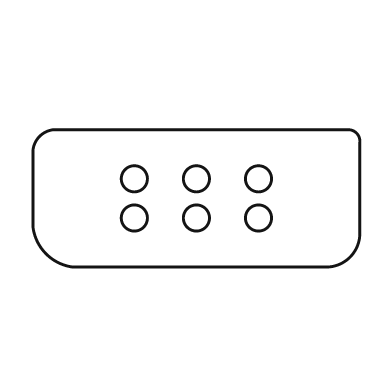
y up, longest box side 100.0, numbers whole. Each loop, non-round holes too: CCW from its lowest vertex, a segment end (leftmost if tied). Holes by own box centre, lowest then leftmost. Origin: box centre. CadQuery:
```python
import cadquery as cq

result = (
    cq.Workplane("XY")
    .moveTo(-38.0, -21.0)
    .lineTo(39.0, -21.0)
    .threePointArc((47.0, -18.0), (50.0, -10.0))
    .lineTo(50.0, 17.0)
    .threePointArc((49.0, 20.0), (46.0, 21.0))
    .lineTo(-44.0, 21.0)
    .threePointArc((-48.0, 19.0), (-50.0, 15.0))
    .lineTo(-50.0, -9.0)
    .threePointArc((-46.0, -17.0), (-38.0, -21.0))
    .close()
    .moveTo(-19.0, -6.0)
    .circle(4.0)
    .moveTo(0.0, -6.0)
    .circle(4.0)
    .moveTo(19.0, -6.0)
    .circle(4.0)
    .moveTo(-19.0, 6.0)
    .circle(4.0)
    .moveTo(0.0, 6.0)
    .circle(4.0)
    .moveTo(19.0, 6.0)
    .circle(4.0)
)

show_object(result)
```